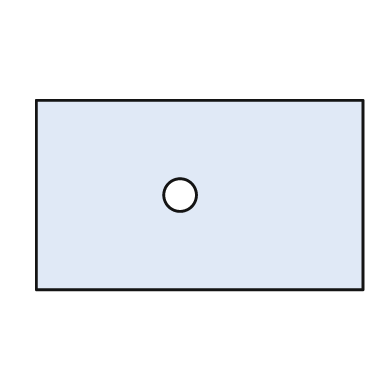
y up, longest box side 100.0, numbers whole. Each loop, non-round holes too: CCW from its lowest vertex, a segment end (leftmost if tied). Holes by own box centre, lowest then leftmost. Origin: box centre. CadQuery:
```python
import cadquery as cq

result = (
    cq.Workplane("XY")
    .moveTo(-50.0, -29.0)
    .lineTo(50.0, -29.0)
    .lineTo(50.0, 29.0)
    .lineTo(-50.0, 29.0)
    .close()
    .moveTo(-6.0, 0.0)
    .circle(5.0)
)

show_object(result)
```